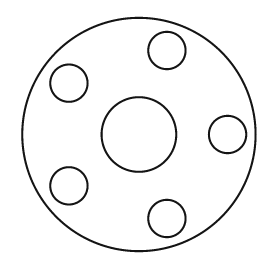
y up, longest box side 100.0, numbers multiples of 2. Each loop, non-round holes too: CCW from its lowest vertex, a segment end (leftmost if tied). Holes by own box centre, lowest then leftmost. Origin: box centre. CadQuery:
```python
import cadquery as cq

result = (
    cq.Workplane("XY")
    .moveTo(0.0, 0.0)
    .circle(50.0)
    .moveTo(12.0, -36.0)
    .circle(8.0)
    .moveTo(-30.0, -22.0)
    .circle(8.0)
    .moveTo(0.0, 0.0)
    .circle(16.0)
    .moveTo(38.0, 0.0)
    .circle(8.0)
    .moveTo(-30.0, 22.0)
    .circle(8.0)
    .moveTo(12.0, 36.0)
    .circle(8.0)
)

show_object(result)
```